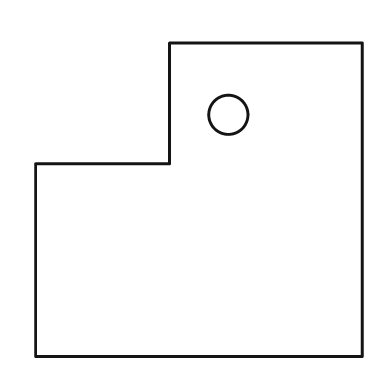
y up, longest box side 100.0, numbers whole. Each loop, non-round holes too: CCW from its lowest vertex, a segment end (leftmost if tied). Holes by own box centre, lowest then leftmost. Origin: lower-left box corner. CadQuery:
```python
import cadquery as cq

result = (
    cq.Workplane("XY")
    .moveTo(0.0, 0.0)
    .lineTo(100.0, 0.0)
    .lineTo(100.0, 96.0)
    .lineTo(41.0, 96.0)
    .lineTo(41.0, 59.0)
    .lineTo(0.0, 59.0)
    .close()
    .moveTo(59.0, 74.0)
    .circle(6.0)
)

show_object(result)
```